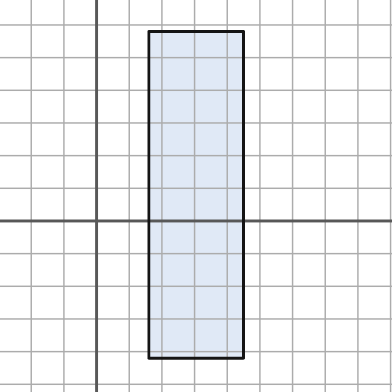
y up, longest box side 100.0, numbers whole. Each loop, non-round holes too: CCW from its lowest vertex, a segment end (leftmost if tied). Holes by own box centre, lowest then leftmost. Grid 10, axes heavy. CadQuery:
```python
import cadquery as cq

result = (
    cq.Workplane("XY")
    .moveTo(16.0, -42.0)
    .lineTo(45.0, -42.0)
    .lineTo(45.0, 58.0)
    .lineTo(16.0, 58.0)
    .close()
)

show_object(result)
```